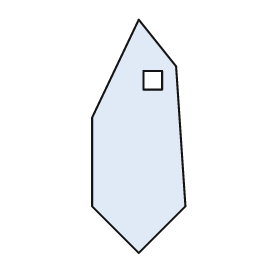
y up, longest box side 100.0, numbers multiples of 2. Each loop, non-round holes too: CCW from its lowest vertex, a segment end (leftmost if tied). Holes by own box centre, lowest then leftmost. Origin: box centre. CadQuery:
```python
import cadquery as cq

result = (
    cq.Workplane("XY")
    .moveTo(0.0, -50.0)
    .lineTo(20.0, -30.0)
    .lineTo(16.0, 30.0)
    .lineTo(0.0, 50.0)
    .lineTo(-20.0, 8.0)
    .lineTo(-20.0, -30.0)
    .close()
    .moveTo(2.0, 20.0)
    .lineTo(10.0, 20.0)
    .lineTo(10.0, 28.0)
    .lineTo(2.0, 28.0)
    .close()
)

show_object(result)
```